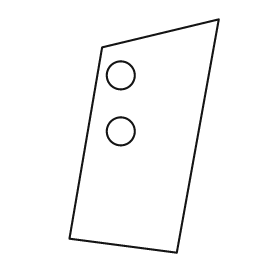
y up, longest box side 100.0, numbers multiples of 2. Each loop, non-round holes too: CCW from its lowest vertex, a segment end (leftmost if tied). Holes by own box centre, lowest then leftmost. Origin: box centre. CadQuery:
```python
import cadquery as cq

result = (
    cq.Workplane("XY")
    .moveTo(14.0, -50.0)
    .lineTo(32.0, 50.0)
    .lineTo(-18.0, 38.0)
    .lineTo(-32.0, -44.0)
    .close()
    .moveTo(-10.0, 2.0)
    .circle(6.0)
    .moveTo(-10.0, 26.0)
    .circle(6.0)
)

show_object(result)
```